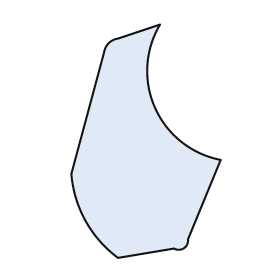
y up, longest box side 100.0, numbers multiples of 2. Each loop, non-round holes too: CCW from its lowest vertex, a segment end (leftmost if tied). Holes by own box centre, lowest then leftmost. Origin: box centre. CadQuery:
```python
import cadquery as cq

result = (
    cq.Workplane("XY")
    .moveTo(-12.0, -50.0)
    .lineTo(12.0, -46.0)
    .threePointArc((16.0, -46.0), (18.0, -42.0))
    .lineTo(32.0, -8.0)
    .threePointArc((4.0, 14.0), (6.0, 50.0))
    .lineTo(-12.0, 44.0)
    .threePointArc((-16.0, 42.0), (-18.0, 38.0))
    .lineTo(-32.0, -14.0)
    .threePointArc((-26.0, -34.0), (-12.0, -50.0))
    .close()
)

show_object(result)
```